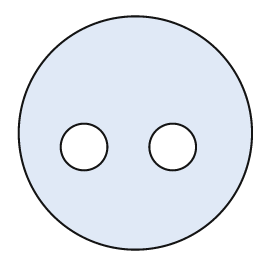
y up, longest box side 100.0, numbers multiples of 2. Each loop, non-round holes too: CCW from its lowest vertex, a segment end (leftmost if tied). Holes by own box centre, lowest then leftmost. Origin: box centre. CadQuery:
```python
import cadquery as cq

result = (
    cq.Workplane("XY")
    .moveTo(0.0, 0.0)
    .circle(50.0)
    .moveTo(-22.0, -6.0)
    .circle(10.0)
    .moveTo(16.0, -6.0)
    .circle(10.0)
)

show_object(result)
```